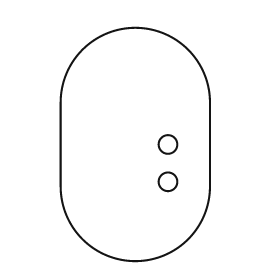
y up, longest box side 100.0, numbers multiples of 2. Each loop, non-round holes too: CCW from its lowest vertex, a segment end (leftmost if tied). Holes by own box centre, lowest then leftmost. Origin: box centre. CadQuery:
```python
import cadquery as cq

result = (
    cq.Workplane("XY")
    .moveTo(-32.0, -18.0)
    .threePointArc((0.0, -50.0), (32.0, -18.0))
    .lineTo(32.0, 18.0)
    .threePointArc((0.0, 50.0), (-32.0, 18.0))
    .close()
    .moveTo(14.0, -16.0)
    .circle(4.0)
    .moveTo(14.0, 0.0)
    .circle(4.0)
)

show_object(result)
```